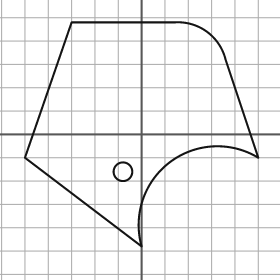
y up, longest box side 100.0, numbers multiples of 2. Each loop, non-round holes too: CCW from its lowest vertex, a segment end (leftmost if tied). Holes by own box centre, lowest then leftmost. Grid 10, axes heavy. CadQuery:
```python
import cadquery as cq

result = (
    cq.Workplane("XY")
    .moveTo(0.0, -48.0)
    .threePointArc((12.0, -12.0), (50.0, -10.0))
    .lineTo(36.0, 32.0)
    .threePointArc((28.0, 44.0), (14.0, 48.0))
    .lineTo(-30.0, 48.0)
    .lineTo(-50.0, -10.0)
    .close()
    .moveTo(-8.0, -16.0)
    .circle(4.0)
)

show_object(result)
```